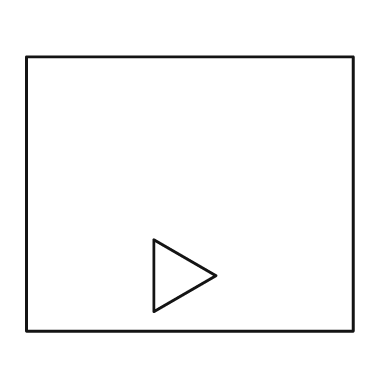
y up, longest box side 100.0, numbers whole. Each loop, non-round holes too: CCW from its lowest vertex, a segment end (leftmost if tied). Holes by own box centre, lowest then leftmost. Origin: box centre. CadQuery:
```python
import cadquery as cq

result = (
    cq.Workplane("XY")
    .moveTo(-50.0, -42.0)
    .lineTo(50.0, -42.0)
    .lineTo(50.0, 42.0)
    .lineTo(-50.0, 42.0)
    .close()
    .moveTo(-11.0, -36.0)
    .lineTo(8.0, -25.0)
    .lineTo(-11.0, -14.0)
    .close()
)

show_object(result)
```